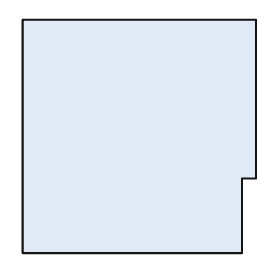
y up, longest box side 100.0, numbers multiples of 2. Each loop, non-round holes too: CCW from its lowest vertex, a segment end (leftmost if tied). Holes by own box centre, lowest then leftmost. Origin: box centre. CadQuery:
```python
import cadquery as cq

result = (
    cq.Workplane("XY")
    .moveTo(-50.0, -50.0)
    .lineTo(44.0, -50.0)
    .lineTo(44.0, -18.0)
    .lineTo(50.0, -18.0)
    .lineTo(50.0, 50.0)
    .lineTo(-50.0, 50.0)
    .close()
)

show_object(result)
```